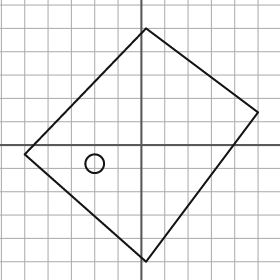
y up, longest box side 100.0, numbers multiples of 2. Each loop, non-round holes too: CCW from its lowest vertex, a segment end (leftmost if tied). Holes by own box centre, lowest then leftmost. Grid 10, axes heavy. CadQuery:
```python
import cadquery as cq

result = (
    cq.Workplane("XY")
    .moveTo(2.0, -50.0)
    .lineTo(50.0, 14.0)
    .lineTo(2.0, 50.0)
    .lineTo(-50.0, -4.0)
    .close()
    .moveTo(-20.0, -8.0)
    .circle(4.0)
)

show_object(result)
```